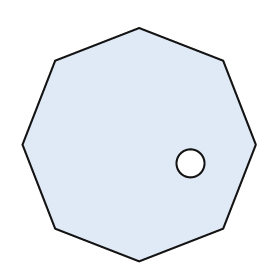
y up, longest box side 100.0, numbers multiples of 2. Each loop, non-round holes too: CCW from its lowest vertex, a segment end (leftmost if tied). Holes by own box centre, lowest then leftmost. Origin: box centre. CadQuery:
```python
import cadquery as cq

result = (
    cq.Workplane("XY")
    .moveTo(0.0, -50.0)
    .lineTo(36.0, -36.0)
    .lineTo(50.0, 0.0)
    .lineTo(36.0, 36.0)
    .lineTo(0.0, 50.0)
    .lineTo(-36.0, 36.0)
    .lineTo(-50.0, 0.0)
    .lineTo(-36.0, -36.0)
    .close()
    .moveTo(22.0, -8.0)
    .circle(6.0)
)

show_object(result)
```